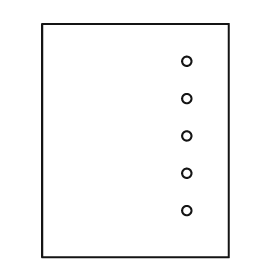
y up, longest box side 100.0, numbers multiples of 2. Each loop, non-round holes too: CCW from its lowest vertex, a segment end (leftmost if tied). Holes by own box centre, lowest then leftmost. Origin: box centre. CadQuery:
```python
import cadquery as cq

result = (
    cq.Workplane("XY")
    .moveTo(-40.0, -50.0)
    .lineTo(40.0, -50.0)
    .lineTo(40.0, 50.0)
    .lineTo(-40.0, 50.0)
    .close()
    .moveTo(22.0, -30.0)
    .circle(2.0)
    .moveTo(22.0, -14.0)
    .circle(2.0)
    .moveTo(22.0, 2.0)
    .circle(2.0)
    .moveTo(22.0, 18.0)
    .circle(2.0)
    .moveTo(22.0, 34.0)
    .circle(2.0)
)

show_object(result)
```